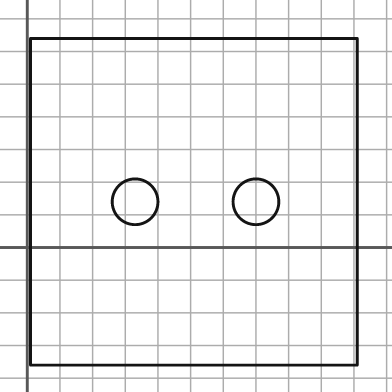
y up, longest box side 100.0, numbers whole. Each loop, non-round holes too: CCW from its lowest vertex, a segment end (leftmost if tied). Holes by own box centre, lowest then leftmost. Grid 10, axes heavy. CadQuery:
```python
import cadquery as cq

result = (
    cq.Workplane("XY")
    .moveTo(1.0, -36.0)
    .lineTo(101.0, -36.0)
    .lineTo(101.0, 64.0)
    .lineTo(1.0, 64.0)
    .close()
    .moveTo(33.0, 14.0)
    .circle(7.0)
    .moveTo(70.0, 14.0)
    .circle(7.0)
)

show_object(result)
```